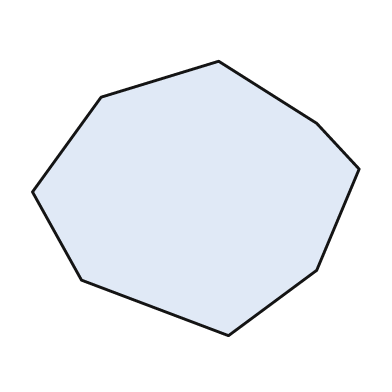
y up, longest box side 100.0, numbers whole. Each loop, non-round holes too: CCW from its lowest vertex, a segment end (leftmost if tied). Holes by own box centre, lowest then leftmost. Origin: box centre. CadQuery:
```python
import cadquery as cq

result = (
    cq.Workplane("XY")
    .moveTo(10.0, -42.0)
    .lineTo(37.0, -22.0)
    .lineTo(50.0, 9.0)
    .lineTo(37.0, 23.0)
    .lineTo(7.0, 42.0)
    .lineTo(-29.0, 31.0)
    .lineTo(-50.0, 2.0)
    .lineTo(-35.0, -25.0)
    .close()
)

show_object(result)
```